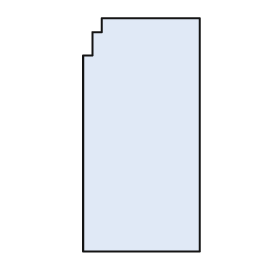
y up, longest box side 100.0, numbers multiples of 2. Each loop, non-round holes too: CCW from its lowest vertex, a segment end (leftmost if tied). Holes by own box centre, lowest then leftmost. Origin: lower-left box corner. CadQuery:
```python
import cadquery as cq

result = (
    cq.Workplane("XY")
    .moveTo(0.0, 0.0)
    .lineTo(50.0, 0.0)
    .lineTo(50.0, 100.0)
    .lineTo(8.0, 100.0)
    .lineTo(8.0, 94.0)
    .lineTo(4.0, 94.0)
    .lineTo(4.0, 84.0)
    .lineTo(0.0, 84.0)
    .close()
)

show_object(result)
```